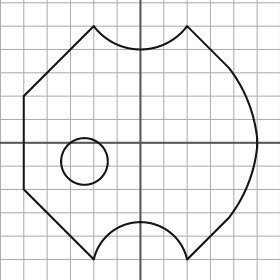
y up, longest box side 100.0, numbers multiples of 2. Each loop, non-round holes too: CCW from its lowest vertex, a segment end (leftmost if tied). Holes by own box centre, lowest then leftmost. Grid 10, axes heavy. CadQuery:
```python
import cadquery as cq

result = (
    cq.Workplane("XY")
    .moveTo(-20.0, -50.0)
    .threePointArc((0.0, -34.0), (20.0, -50.0))
    .lineTo(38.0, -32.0)
    .threePointArc((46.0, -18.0), (50.0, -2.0))
    .lineTo(50.0, 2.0)
    .threePointArc((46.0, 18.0), (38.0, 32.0))
    .lineTo(20.0, 50.0)
    .threePointArc((0.0, 40.0), (-20.0, 50.0))
    .lineTo(-50.0, 20.0)
    .lineTo(-50.0, -20.0)
    .close()
    .moveTo(-24.0, -8.0)
    .circle(10.0)
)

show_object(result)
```